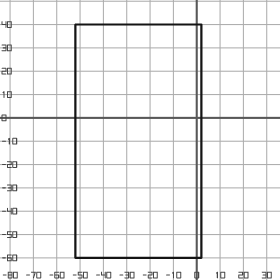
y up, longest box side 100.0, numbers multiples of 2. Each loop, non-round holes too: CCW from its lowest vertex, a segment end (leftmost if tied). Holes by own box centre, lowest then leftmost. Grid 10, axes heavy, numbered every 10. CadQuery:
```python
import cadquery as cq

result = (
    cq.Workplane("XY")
    .moveTo(-52.0, -60.0)
    .lineTo(2.0, -60.0)
    .lineTo(2.0, 40.0)
    .lineTo(-52.0, 40.0)
    .close()
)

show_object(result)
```